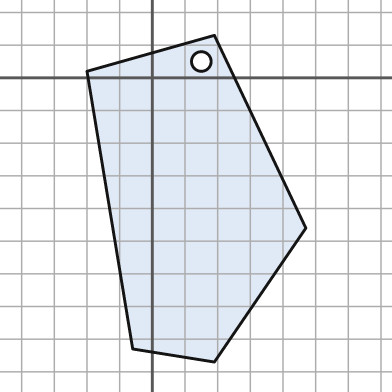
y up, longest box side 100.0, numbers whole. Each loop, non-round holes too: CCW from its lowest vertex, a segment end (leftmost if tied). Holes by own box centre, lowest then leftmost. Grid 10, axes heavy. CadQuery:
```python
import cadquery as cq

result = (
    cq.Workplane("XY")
    .moveTo(19.0, -87.0)
    .lineTo(47.0, -46.0)
    .lineTo(19.0, 13.0)
    .lineTo(-20.0, 2.0)
    .lineTo(-6.0, -83.0)
    .close()
    .moveTo(15.0, 5.0)
    .circle(3.0)
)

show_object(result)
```